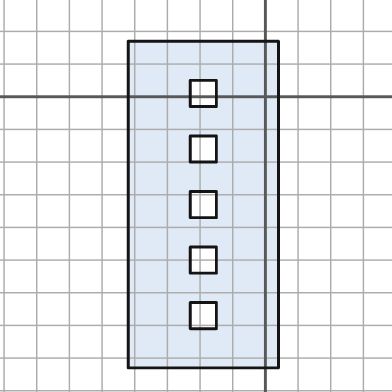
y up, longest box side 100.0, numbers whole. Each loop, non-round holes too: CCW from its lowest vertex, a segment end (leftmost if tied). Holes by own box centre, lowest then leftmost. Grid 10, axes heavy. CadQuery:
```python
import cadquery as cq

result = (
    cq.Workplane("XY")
    .moveTo(-42.0, -83.0)
    .lineTo(4.0, -83.0)
    .lineTo(4.0, 17.0)
    .lineTo(-42.0, 17.0)
    .close()
    .moveTo(-23.0, -71.0)
    .lineTo(-15.0, -71.0)
    .lineTo(-15.0, -63.0)
    .lineTo(-23.0, -63.0)
    .close()
    .moveTo(-23.0, -54.0)
    .lineTo(-15.0, -54.0)
    .lineTo(-15.0, -46.0)
    .lineTo(-23.0, -46.0)
    .close()
    .moveTo(-23.0, -37.0)
    .lineTo(-15.0, -37.0)
    .lineTo(-15.0, -29.0)
    .lineTo(-23.0, -29.0)
    .close()
    .moveTo(-23.0, -20.0)
    .lineTo(-15.0, -20.0)
    .lineTo(-15.0, -12.0)
    .lineTo(-23.0, -12.0)
    .close()
    .moveTo(-23.0, -3.0)
    .lineTo(-15.0, -3.0)
    .lineTo(-15.0, 5.0)
    .lineTo(-23.0, 5.0)
    .close()
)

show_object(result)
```